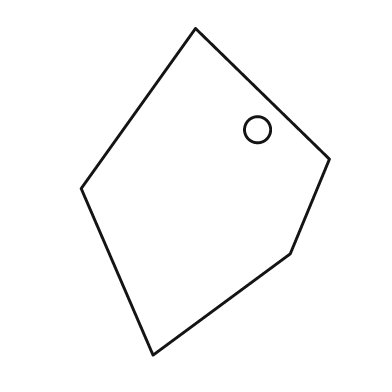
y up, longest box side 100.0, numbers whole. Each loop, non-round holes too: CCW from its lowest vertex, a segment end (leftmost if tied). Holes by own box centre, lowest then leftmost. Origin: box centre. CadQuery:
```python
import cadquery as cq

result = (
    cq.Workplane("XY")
    .moveTo(-16.0, -50.0)
    .lineTo(26.0, -19.0)
    .lineTo(38.0, 10.0)
    .lineTo(-3.0, 50.0)
    .lineTo(-38.0, 1.0)
    .close()
    .moveTo(16.0, 19.0)
    .circle(4.0)
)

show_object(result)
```